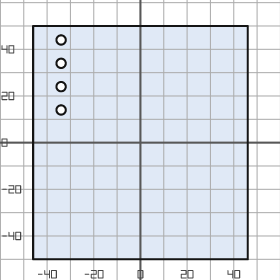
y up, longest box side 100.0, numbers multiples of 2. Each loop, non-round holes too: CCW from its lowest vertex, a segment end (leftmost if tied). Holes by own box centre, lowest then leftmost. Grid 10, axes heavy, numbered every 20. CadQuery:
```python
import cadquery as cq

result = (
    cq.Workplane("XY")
    .moveTo(-46.0, -50.0)
    .lineTo(46.0, -50.0)
    .lineTo(46.0, 50.0)
    .lineTo(-46.0, 50.0)
    .close()
    .moveTo(-34.0, 14.0)
    .circle(2.0)
    .moveTo(-34.0, 24.0)
    .circle(2.0)
    .moveTo(-34.0, 34.0)
    .circle(2.0)
    .moveTo(-34.0, 44.0)
    .circle(2.0)
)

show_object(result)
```